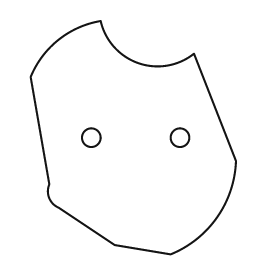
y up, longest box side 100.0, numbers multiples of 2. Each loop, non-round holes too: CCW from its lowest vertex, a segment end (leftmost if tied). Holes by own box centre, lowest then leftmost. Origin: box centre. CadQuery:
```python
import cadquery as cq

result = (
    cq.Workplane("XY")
    .moveTo(16.0, -50.0)
    .threePointArc((36.0, -34.0), (44.0, -10.0))
    .lineTo(26.0, 36.0)
    .threePointArc((2.0, 32.0), (-14.0, 50.0))
    .threePointArc((-32.0, 42.0), (-44.0, 26.0))
    .lineTo(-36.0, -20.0)
    .threePointArc((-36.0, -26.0), (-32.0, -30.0))
    .lineTo(-8.0, -46.0)
    .close()
    .moveTo(-18.0, 0.0)
    .circle(4.0)
    .moveTo(20.0, 0.0)
    .circle(4.0)
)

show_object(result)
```